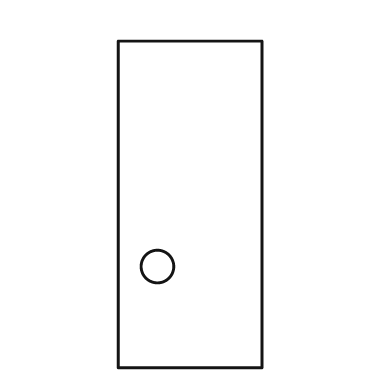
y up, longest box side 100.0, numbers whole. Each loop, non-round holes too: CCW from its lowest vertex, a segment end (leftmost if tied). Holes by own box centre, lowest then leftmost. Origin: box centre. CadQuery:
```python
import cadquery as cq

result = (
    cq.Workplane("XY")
    .moveTo(-22.0, -50.0)
    .lineTo(22.0, -50.0)
    .lineTo(22.0, 50.0)
    .lineTo(-22.0, 50.0)
    .close()
    .moveTo(-10.0, -19.0)
    .circle(5.0)
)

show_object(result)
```